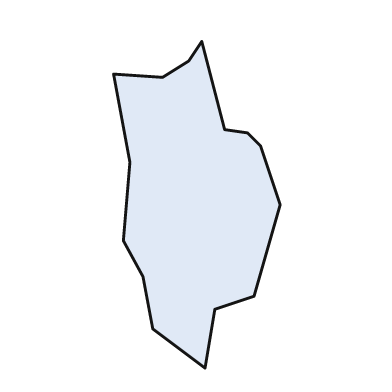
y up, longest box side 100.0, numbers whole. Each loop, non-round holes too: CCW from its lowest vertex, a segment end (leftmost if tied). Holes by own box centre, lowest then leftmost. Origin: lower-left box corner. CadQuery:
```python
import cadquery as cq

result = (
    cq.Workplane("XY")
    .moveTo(28.0, 0.0)
    .lineTo(31.0, 18.0)
    .lineTo(43.0, 22.0)
    .lineTo(51.0, 50.0)
    .lineTo(45.0, 68.0)
    .lineTo(41.0, 72.0)
    .lineTo(34.0, 73.0)
    .lineTo(27.0, 100.0)
    .lineTo(23.0, 94.0)
    .lineTo(15.0, 89.0)
    .lineTo(0.0, 90.0)
    .lineTo(5.0, 63.0)
    .lineTo(3.0, 39.0)
    .lineTo(9.0, 28.0)
    .lineTo(12.0, 12.0)
    .close()
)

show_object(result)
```